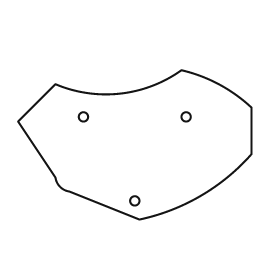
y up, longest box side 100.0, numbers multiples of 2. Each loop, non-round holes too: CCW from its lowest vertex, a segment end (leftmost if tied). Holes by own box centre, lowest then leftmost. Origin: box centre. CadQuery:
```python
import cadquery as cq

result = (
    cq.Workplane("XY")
    .moveTo(2.0, -32.0)
    .threePointArc((28.0, -22.0), (50.0, -4.0))
    .lineTo(50.0, 16.0)
    .threePointArc((36.0, 26.0), (20.0, 32.0))
    .threePointArc((-6.0, 22.0), (-34.0, 26.0))
    .lineTo(-50.0, 10.0)
    .lineTo(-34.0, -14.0)
    .threePointArc((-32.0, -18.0), (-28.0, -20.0))
    .close()
    .moveTo(0.0, -24.0)
    .circle(2.0)
    .moveTo(-22.0, 12.0)
    .circle(2.0)
    .moveTo(22.0, 12.0)
    .circle(2.0)
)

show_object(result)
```